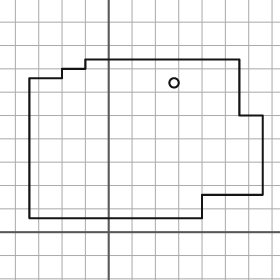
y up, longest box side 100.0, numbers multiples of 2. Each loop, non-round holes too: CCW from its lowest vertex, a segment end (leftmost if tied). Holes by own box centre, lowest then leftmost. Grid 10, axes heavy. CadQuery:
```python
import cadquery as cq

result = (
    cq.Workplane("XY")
    .moveTo(-34.0, 6.0)
    .lineTo(40.0, 6.0)
    .lineTo(40.0, 16.0)
    .lineTo(66.0, 16.0)
    .lineTo(66.0, 50.0)
    .lineTo(56.0, 50.0)
    .lineTo(56.0, 74.0)
    .lineTo(-10.0, 74.0)
    .lineTo(-10.0, 70.0)
    .lineTo(-20.0, 70.0)
    .lineTo(-20.0, 66.0)
    .lineTo(-34.0, 66.0)
    .close()
    .moveTo(28.0, 64.0)
    .circle(2.0)
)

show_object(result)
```